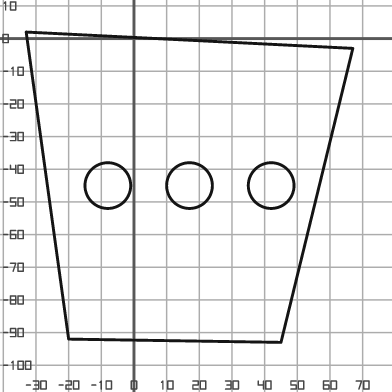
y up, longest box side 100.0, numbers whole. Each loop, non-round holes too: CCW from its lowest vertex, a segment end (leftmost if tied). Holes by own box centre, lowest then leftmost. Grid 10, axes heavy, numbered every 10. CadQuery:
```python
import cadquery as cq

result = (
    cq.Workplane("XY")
    .moveTo(45.0, -93.0)
    .lineTo(67.0, -3.0)
    .lineTo(-33.0, 2.0)
    .lineTo(-20.0, -92.0)
    .close()
    .moveTo(-8.0, -45.0)
    .circle(7.0)
    .moveTo(17.0, -45.0)
    .circle(7.0)
    .moveTo(42.0, -45.0)
    .circle(7.0)
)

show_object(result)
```